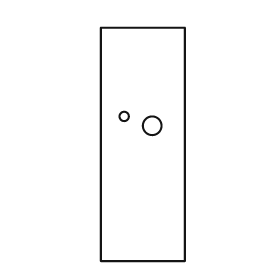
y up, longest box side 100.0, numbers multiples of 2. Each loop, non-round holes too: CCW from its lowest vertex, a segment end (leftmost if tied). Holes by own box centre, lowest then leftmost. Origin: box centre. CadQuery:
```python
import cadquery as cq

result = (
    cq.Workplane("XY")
    .moveTo(-18.0, -50.0)
    .lineTo(18.0, -50.0)
    .lineTo(18.0, 50.0)
    .lineTo(-18.0, 50.0)
    .close()
    .moveTo(4.0, 8.0)
    .circle(4.0)
    .moveTo(-8.0, 12.0)
    .circle(2.0)
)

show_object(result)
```